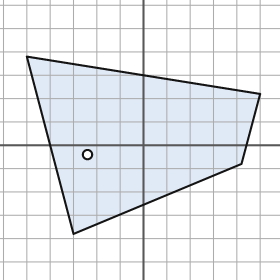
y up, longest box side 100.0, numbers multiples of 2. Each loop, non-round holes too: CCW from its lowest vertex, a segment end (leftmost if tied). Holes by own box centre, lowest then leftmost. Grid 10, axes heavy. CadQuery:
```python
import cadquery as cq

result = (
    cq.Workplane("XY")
    .moveTo(-30.0, -38.0)
    .lineTo(42.0, -8.0)
    .lineTo(50.0, 22.0)
    .lineTo(-50.0, 38.0)
    .close()
    .moveTo(-24.0, -4.0)
    .circle(2.0)
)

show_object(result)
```